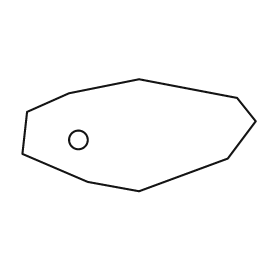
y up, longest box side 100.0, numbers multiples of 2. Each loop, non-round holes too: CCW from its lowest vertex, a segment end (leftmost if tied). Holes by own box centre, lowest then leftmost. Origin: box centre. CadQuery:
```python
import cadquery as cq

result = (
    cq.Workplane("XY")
    .moveTo(0.0, -24.0)
    .lineTo(38.0, -10.0)
    .lineTo(50.0, 6.0)
    .lineTo(42.0, 16.0)
    .lineTo(0.0, 24.0)
    .lineTo(-30.0, 18.0)
    .lineTo(-48.0, 10.0)
    .lineTo(-50.0, -8.0)
    .lineTo(-22.0, -20.0)
    .close()
    .moveTo(-26.0, -2.0)
    .circle(4.0)
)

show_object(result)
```